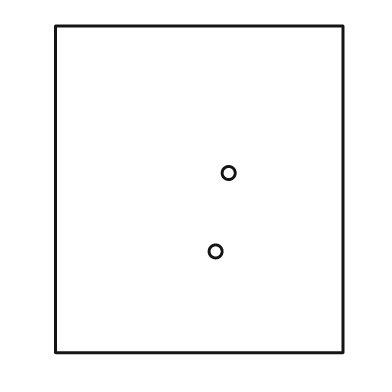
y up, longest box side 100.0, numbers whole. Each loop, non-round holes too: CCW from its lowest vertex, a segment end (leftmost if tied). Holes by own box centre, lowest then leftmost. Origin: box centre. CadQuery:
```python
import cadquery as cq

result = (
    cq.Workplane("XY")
    .moveTo(-44.0, -50.0)
    .lineTo(44.0, -50.0)
    .lineTo(44.0, 50.0)
    .lineTo(-44.0, 50.0)
    .close()
    .moveTo(5.0, -19.0)
    .circle(2.0)
    .moveTo(9.0, 5.0)
    .circle(2.0)
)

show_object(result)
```